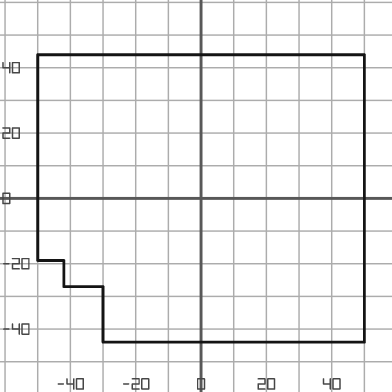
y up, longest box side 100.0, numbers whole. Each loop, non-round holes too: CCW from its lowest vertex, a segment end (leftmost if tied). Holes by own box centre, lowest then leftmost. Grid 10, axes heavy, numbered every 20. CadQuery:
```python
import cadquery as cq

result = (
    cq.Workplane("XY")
    .moveTo(-30.0, -44.0)
    .lineTo(50.0, -44.0)
    .lineTo(50.0, 44.0)
    .lineTo(-50.0, 44.0)
    .lineTo(-50.0, -19.0)
    .lineTo(-42.0, -19.0)
    .lineTo(-42.0, -27.0)
    .lineTo(-30.0, -27.0)
    .close()
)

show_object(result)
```